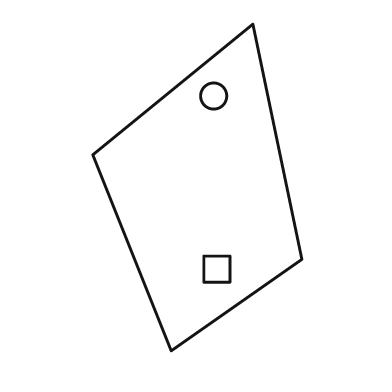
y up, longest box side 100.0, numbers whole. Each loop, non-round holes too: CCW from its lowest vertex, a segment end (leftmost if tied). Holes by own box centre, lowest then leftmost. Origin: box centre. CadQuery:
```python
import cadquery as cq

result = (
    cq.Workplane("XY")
    .moveTo(-8.0, -50.0)
    .lineTo(32.0, -22.0)
    .lineTo(17.0, 50.0)
    .lineTo(-32.0, 10.0)
    .close()
    .moveTo(2.0, -29.0)
    .lineTo(10.0, -29.0)
    .lineTo(10.0, -21.0)
    .lineTo(2.0, -21.0)
    .close()
    .moveTo(5.0, 28.0)
    .circle(4.0)
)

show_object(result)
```